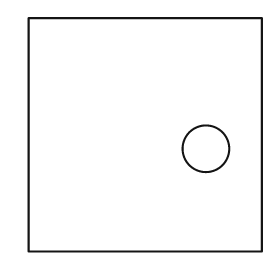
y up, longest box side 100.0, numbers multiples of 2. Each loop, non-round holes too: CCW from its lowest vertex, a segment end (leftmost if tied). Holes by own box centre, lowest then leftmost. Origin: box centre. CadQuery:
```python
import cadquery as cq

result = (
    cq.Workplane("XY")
    .moveTo(-50.0, -50.0)
    .lineTo(50.0, -50.0)
    .lineTo(50.0, 50.0)
    .lineTo(-50.0, 50.0)
    .close()
    .moveTo(26.0, -6.0)
    .circle(10.0)
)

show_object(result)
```